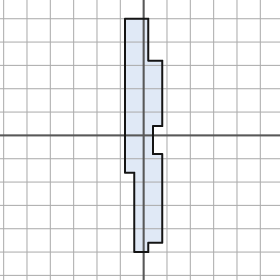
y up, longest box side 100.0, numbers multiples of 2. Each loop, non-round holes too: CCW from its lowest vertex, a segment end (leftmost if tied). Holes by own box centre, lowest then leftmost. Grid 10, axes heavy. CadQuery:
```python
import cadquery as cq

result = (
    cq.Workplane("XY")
    .moveTo(-4.0, -50.0)
    .lineTo(2.0, -50.0)
    .lineTo(2.0, -46.0)
    .lineTo(8.0, -46.0)
    .lineTo(8.0, -8.0)
    .lineTo(4.0, -8.0)
    .lineTo(4.0, 4.0)
    .lineTo(8.0, 4.0)
    .lineTo(8.0, 32.0)
    .lineTo(2.0, 32.0)
    .lineTo(2.0, 50.0)
    .lineTo(-8.0, 50.0)
    .lineTo(-8.0, -16.0)
    .lineTo(-4.0, -16.0)
    .close()
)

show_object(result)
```